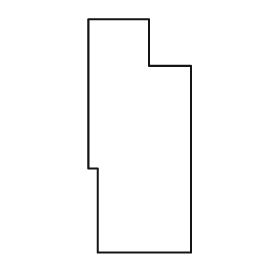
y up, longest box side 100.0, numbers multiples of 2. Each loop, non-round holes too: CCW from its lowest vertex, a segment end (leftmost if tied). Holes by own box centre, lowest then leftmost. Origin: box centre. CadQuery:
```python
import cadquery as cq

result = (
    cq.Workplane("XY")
    .moveTo(-18.0, -50.0)
    .lineTo(22.0, -50.0)
    .lineTo(22.0, 30.0)
    .lineTo(4.0, 30.0)
    .lineTo(4.0, 50.0)
    .lineTo(-22.0, 50.0)
    .lineTo(-22.0, -14.0)
    .lineTo(-18.0, -14.0)
    .close()
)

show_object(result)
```